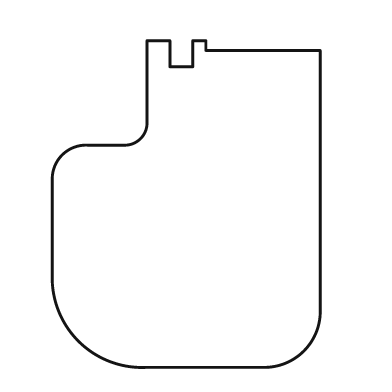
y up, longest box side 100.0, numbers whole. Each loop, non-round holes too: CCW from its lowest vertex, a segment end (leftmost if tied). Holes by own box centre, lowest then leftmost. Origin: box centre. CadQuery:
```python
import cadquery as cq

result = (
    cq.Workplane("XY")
    .moveTo(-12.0, -50.0)
    .lineTo(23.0, -50.0)
    .threePointArc((36.0, -45.0), (41.0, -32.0))
    .lineTo(41.0, 47.0)
    .lineTo(6.0, 47.0)
    .lineTo(6.0, 50.0)
    .lineTo(2.0, 50.0)
    .lineTo(2.0, 42.0)
    .lineTo(-5.0, 42.0)
    .lineTo(-5.0, 50.0)
    .lineTo(-12.0, 50.0)
    .lineTo(-12.0, 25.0)
    .threePointArc((-14.0, 20.0), (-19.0, 18.0))
    .lineTo(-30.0, 18.0)
    .threePointArc((-38.0, 15.0), (-41.0, 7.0))
    .lineTo(-41.0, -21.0)
    .threePointArc((-33.0, -42.0), (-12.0, -50.0))
    .close()
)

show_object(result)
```